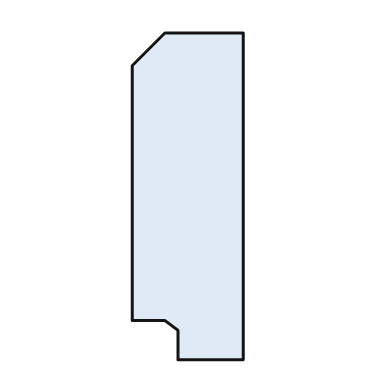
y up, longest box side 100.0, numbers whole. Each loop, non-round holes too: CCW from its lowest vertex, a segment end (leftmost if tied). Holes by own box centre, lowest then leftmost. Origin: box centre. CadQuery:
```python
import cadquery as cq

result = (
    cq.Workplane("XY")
    .moveTo(-3.0, -50.0)
    .lineTo(17.0, -50.0)
    .lineTo(17.0, 50.0)
    .lineTo(-7.0, 50.0)
    .lineTo(-17.0, 40.0)
    .lineTo(-17.0, -38.0)
    .lineTo(-7.0, -38.0)
    .lineTo(-3.0, -41.0)
    .close()
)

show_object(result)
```